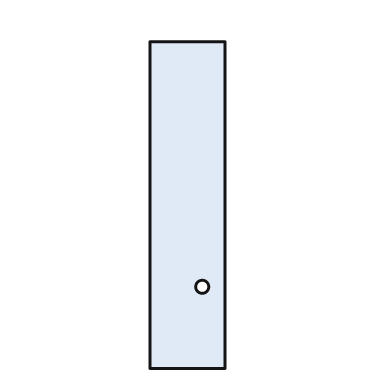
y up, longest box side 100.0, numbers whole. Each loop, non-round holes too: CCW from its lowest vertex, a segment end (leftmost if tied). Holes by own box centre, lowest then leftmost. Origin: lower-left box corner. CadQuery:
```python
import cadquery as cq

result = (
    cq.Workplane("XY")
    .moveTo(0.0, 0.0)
    .lineTo(23.0, 0.0)
    .lineTo(23.0, 100.0)
    .lineTo(0.0, 100.0)
    .close()
    .moveTo(16.0, 25.0)
    .circle(2.0)
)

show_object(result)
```